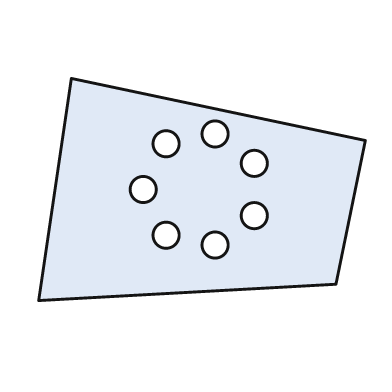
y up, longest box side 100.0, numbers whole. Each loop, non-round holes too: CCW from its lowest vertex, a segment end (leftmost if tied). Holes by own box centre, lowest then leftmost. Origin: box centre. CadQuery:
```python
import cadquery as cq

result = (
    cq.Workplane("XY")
    .moveTo(-50.0, -34.0)
    .lineTo(41.0, -29.0)
    .lineTo(50.0, 15.0)
    .lineTo(-40.0, 34.0)
    .close()
    .moveTo(4.0, -17.0)
    .circle(4.0)
    .moveTo(-11.0, -14.0)
    .circle(4.0)
    .moveTo(16.0, -8.0)
    .circle(4.0)
    .moveTo(-18.0, 0.0)
    .circle(4.0)
    .moveTo(16.0, 8.0)
    .circle(4.0)
    .moveTo(-11.0, 14.0)
    .circle(4.0)
    .moveTo(4.0, 17.0)
    .circle(4.0)
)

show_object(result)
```